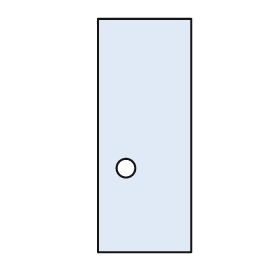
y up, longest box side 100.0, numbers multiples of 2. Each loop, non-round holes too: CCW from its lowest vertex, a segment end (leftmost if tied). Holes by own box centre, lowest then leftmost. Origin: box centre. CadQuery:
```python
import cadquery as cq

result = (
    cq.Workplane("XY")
    .moveTo(-20.0, -50.0)
    .lineTo(20.0, -50.0)
    .lineTo(20.0, 50.0)
    .lineTo(-20.0, 50.0)
    .close()
    .moveTo(-8.0, -14.0)
    .circle(4.0)
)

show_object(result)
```